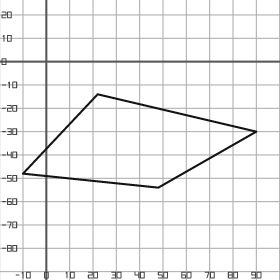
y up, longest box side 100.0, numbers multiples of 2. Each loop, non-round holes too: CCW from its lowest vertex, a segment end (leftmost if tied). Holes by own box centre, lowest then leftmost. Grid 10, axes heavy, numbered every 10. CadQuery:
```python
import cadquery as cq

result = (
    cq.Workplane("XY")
    .moveTo(48.0, -54.0)
    .lineTo(90.0, -30.0)
    .lineTo(22.0, -14.0)
    .lineTo(-10.0, -48.0)
    .close()
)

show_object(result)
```